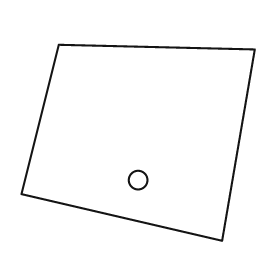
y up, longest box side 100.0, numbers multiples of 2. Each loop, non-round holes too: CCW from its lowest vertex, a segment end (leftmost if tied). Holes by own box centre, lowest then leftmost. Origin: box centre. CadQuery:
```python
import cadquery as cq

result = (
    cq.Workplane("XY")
    .moveTo(36.0, -42.0)
    .lineTo(50.0, 40.0)
    .lineTo(-34.0, 42.0)
    .lineTo(-50.0, -22.0)
    .close()
    .moveTo(0.0, -16.0)
    .circle(4.0)
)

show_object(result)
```